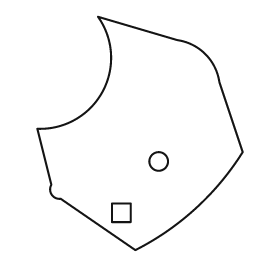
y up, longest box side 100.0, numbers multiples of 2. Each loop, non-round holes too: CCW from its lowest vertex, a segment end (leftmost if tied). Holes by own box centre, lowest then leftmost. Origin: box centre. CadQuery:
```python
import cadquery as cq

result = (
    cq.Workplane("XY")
    .moveTo(-2.0, -50.0)
    .threePointArc((24.0, -32.0), (44.0, -8.0))
    .lineTo(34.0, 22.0)
    .threePointArc((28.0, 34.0), (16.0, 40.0))
    .lineTo(-18.0, 50.0)
    .threePointArc((-16.0, 18.0), (-44.0, 2.0))
    .lineTo(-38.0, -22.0)
    .threePointArc((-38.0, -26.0), (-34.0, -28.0))
    .close()
    .moveTo(-12.0, -38.0)
    .lineTo(-4.0, -38.0)
    .lineTo(-4.0, -30.0)
    .lineTo(-12.0, -30.0)
    .close()
    .moveTo(8.0, -12.0)
    .circle(4.0)
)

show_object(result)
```